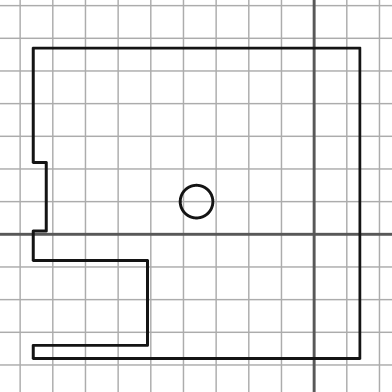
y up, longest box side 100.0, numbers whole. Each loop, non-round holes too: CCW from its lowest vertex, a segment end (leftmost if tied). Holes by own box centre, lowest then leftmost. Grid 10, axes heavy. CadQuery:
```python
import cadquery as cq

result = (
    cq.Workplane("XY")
    .moveTo(-86.0, -38.0)
    .lineTo(14.0, -38.0)
    .lineTo(14.0, 57.0)
    .lineTo(-86.0, 57.0)
    .lineTo(-86.0, 22.0)
    .lineTo(-82.0, 22.0)
    .lineTo(-82.0, 1.0)
    .lineTo(-86.0, 1.0)
    .lineTo(-86.0, -8.0)
    .lineTo(-51.0, -8.0)
    .lineTo(-51.0, -34.0)
    .lineTo(-86.0, -34.0)
    .close()
    .moveTo(-36.0, 10.0)
    .circle(5.0)
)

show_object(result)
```